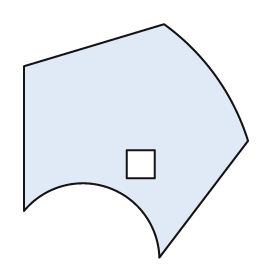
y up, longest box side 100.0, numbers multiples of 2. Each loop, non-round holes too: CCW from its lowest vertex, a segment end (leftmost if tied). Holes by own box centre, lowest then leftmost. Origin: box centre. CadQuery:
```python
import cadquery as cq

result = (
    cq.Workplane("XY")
    .moveTo(10.0, -50.0)
    .lineTo(48.0, 0.0)
    .threePointArc((34.0, 28.0), (12.0, 50.0))
    .lineTo(-48.0, 32.0)
    .lineTo(-48.0, -30.0)
    .threePointArc((-12.0, -20.0), (10.0, -50.0))
    .close()
    .moveTo(-4.0, -16.0)
    .lineTo(8.0, -16.0)
    .lineTo(8.0, -4.0)
    .lineTo(-4.0, -4.0)
    .close()
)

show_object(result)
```